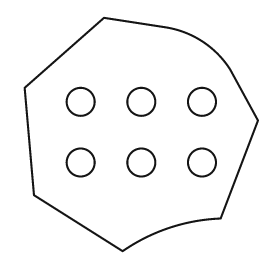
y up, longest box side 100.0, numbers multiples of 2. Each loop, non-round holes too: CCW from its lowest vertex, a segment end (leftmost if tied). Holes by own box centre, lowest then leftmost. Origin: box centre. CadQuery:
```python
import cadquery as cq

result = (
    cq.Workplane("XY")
    .moveTo(-8.0, -50.0)
    .threePointArc((12.0, -40.0), (34.0, -36.0))
    .lineTo(50.0, 6.0)
    .lineTo(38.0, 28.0)
    .threePointArc((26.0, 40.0), (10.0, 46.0))
    .lineTo(-16.0, 50.0)
    .lineTo(-50.0, 20.0)
    .lineTo(-46.0, -26.0)
    .close()
    .moveTo(-26.0, -12.0)
    .circle(6.0)
    .moveTo(0.0, -12.0)
    .circle(6.0)
    .moveTo(26.0, -12.0)
    .circle(6.0)
    .moveTo(-26.0, 14.0)
    .circle(6.0)
    .moveTo(0.0, 14.0)
    .circle(6.0)
    .moveTo(26.0, 14.0)
    .circle(6.0)
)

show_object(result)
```